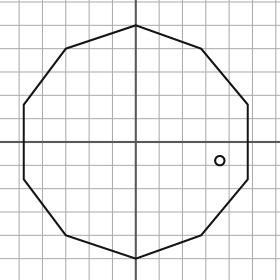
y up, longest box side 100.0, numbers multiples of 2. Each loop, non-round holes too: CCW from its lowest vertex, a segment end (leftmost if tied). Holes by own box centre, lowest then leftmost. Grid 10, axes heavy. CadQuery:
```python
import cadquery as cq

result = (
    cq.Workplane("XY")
    .moveTo(0.0, -50.0)
    .lineTo(28.0, -40.0)
    .lineTo(48.0, -16.0)
    .lineTo(48.0, 16.0)
    .lineTo(28.0, 40.0)
    .lineTo(0.0, 50.0)
    .lineTo(-30.0, 40.0)
    .lineTo(-48.0, 16.0)
    .lineTo(-48.0, -16.0)
    .lineTo(-30.0, -40.0)
    .close()
    .moveTo(36.0, -8.0)
    .circle(2.0)
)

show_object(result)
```